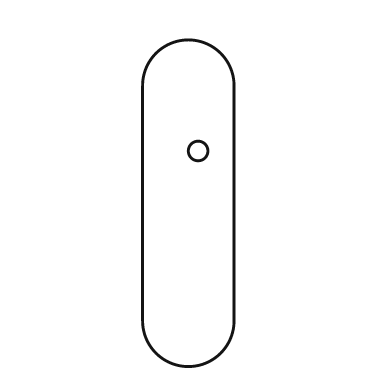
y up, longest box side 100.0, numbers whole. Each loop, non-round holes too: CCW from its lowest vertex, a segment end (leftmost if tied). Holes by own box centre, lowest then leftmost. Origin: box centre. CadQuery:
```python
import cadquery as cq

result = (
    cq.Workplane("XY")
    .moveTo(-14.0, -36.0)
    .threePointArc((0.0, -50.0), (14.0, -36.0))
    .lineTo(14.0, 36.0)
    .threePointArc((0.0, 50.0), (-14.0, 36.0))
    .close()
    .moveTo(3.0, 16.0)
    .circle(3.0)
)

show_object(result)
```